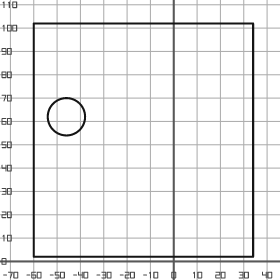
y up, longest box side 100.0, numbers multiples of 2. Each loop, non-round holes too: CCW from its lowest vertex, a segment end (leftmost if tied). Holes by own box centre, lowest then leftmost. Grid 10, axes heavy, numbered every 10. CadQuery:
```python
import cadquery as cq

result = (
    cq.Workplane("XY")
    .moveTo(-60.0, 2.0)
    .lineTo(34.0, 2.0)
    .lineTo(34.0, 102.0)
    .lineTo(-60.0, 102.0)
    .close()
    .moveTo(-46.0, 62.0)
    .circle(8.0)
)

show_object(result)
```